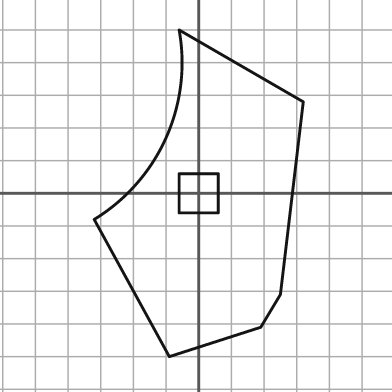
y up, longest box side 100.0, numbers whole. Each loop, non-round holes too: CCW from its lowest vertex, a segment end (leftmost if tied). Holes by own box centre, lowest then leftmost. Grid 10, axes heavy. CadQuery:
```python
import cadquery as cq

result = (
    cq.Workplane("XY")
    .moveTo(-9.0, -50.0)
    .lineTo(19.0, -41.0)
    .lineTo(25.0, -31.0)
    .lineTo(32.0, 28.0)
    .lineTo(-6.0, 50.0)
    .threePointArc((-10.0, 17.0), (-32.0, -8.0))
    .close()
    .moveTo(-6.0, -6.0)
    .lineTo(6.0, -6.0)
    .lineTo(6.0, 6.0)
    .lineTo(-6.0, 6.0)
    .close()
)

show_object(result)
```